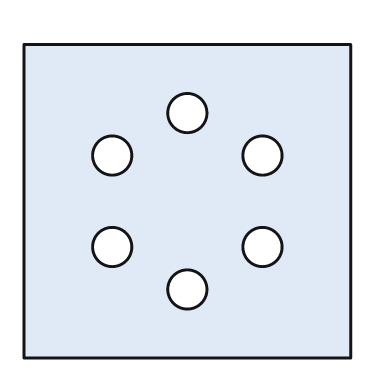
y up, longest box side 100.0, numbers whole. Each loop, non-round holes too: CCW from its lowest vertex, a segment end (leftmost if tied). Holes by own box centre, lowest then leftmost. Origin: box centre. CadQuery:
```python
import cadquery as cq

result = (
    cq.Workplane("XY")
    .moveTo(-50.0, -48.0)
    .lineTo(50.0, -48.0)
    .lineTo(50.0, 48.0)
    .lineTo(-50.0, 48.0)
    .close()
    .moveTo(0.0, -27.0)
    .circle(6.0)
    .moveTo(-23.0, -14.0)
    .circle(6.0)
    .moveTo(23.0, -14.0)
    .circle(6.0)
    .moveTo(-23.0, 14.0)
    .circle(6.0)
    .moveTo(23.0, 14.0)
    .circle(6.0)
    .moveTo(0.0, 27.0)
    .circle(6.0)
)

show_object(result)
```